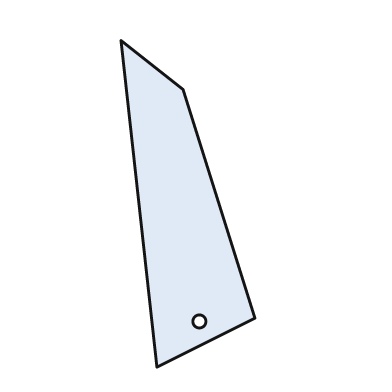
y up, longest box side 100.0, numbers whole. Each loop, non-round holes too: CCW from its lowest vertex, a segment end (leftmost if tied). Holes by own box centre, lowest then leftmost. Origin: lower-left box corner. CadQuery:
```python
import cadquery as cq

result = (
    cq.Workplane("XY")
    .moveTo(11.0, 0.0)
    .lineTo(41.0, 15.0)
    .lineTo(19.0, 85.0)
    .lineTo(0.0, 100.0)
    .close()
    .moveTo(24.0, 14.0)
    .circle(2.0)
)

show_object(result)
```